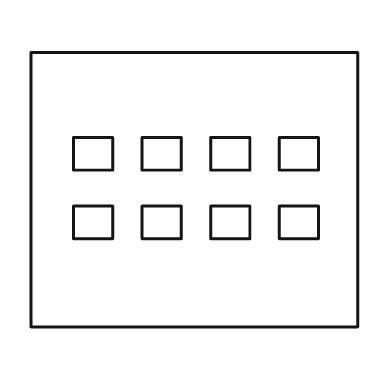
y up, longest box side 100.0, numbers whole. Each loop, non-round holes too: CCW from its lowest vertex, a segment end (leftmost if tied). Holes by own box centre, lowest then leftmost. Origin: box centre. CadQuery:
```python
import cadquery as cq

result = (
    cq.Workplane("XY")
    .moveTo(-50.0, -42.0)
    .lineTo(50.0, -42.0)
    .lineTo(50.0, 42.0)
    .lineTo(-50.0, 42.0)
    .close()
    .moveTo(-37.0, -15.0)
    .lineTo(-25.0, -15.0)
    .lineTo(-25.0, -5.0)
    .lineTo(-37.0, -5.0)
    .close()
    .moveTo(-16.0, -15.0)
    .lineTo(-4.0, -15.0)
    .lineTo(-4.0, -5.0)
    .lineTo(-16.0, -5.0)
    .close()
    .moveTo(5.0, -15.0)
    .lineTo(17.0, -15.0)
    .lineTo(17.0, -5.0)
    .lineTo(5.0, -5.0)
    .close()
    .moveTo(26.0, -15.0)
    .lineTo(38.0, -15.0)
    .lineTo(38.0, -5.0)
    .lineTo(26.0, -5.0)
    .close()
    .moveTo(-37.0, 6.0)
    .lineTo(-25.0, 6.0)
    .lineTo(-25.0, 16.0)
    .lineTo(-37.0, 16.0)
    .close()
    .moveTo(-16.0, 6.0)
    .lineTo(-4.0, 6.0)
    .lineTo(-4.0, 16.0)
    .lineTo(-16.0, 16.0)
    .close()
    .moveTo(5.0, 6.0)
    .lineTo(17.0, 6.0)
    .lineTo(17.0, 16.0)
    .lineTo(5.0, 16.0)
    .close()
    .moveTo(26.0, 6.0)
    .lineTo(38.0, 6.0)
    .lineTo(38.0, 16.0)
    .lineTo(26.0, 16.0)
    .close()
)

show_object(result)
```